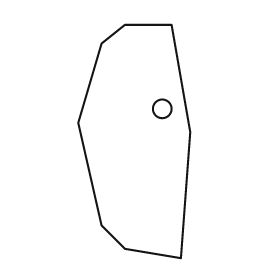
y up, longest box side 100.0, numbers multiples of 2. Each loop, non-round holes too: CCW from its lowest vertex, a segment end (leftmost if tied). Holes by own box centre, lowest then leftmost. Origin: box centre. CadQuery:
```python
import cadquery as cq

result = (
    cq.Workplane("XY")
    .moveTo(20.0, -50.0)
    .lineTo(24.0, 4.0)
    .lineTo(16.0, 50.0)
    .lineTo(-4.0, 50.0)
    .lineTo(-14.0, 42.0)
    .lineTo(-24.0, 8.0)
    .lineTo(-14.0, -36.0)
    .lineTo(-4.0, -46.0)
    .close()
    .moveTo(12.0, 14.0)
    .circle(4.0)
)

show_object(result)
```